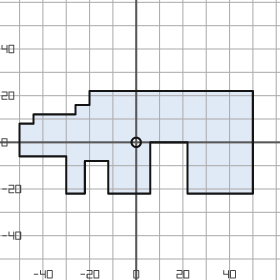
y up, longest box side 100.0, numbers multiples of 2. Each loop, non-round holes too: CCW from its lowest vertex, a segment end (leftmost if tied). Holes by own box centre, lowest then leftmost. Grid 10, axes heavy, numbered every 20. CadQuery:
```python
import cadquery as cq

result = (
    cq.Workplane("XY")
    .moveTo(-30.0, -22.0)
    .lineTo(-22.0, -22.0)
    .lineTo(-22.0, -8.0)
    .lineTo(-12.0, -8.0)
    .lineTo(-12.0, -22.0)
    .lineTo(6.0, -22.0)
    .lineTo(6.0, 0.0)
    .lineTo(22.0, 0.0)
    .lineTo(22.0, -22.0)
    .lineTo(50.0, -22.0)
    .lineTo(50.0, 22.0)
    .lineTo(-20.0, 22.0)
    .lineTo(-20.0, 16.0)
    .lineTo(-26.0, 16.0)
    .lineTo(-26.0, 12.0)
    .lineTo(-44.0, 12.0)
    .lineTo(-44.0, 8.0)
    .lineTo(-50.0, 8.0)
    .lineTo(-50.0, -6.0)
    .lineTo(-30.0, -6.0)
    .close()
    .moveTo(0.0, 0.0)
    .circle(2.0)
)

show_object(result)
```